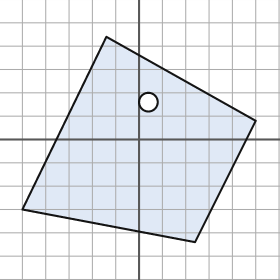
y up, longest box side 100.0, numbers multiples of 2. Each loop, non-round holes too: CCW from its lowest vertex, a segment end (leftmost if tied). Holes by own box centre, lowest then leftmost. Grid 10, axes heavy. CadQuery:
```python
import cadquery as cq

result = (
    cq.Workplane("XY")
    .moveTo(24.0, -44.0)
    .lineTo(50.0, 8.0)
    .lineTo(-14.0, 44.0)
    .lineTo(-50.0, -30.0)
    .close()
    .moveTo(4.0, 16.0)
    .circle(4.0)
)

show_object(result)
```